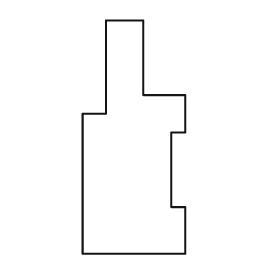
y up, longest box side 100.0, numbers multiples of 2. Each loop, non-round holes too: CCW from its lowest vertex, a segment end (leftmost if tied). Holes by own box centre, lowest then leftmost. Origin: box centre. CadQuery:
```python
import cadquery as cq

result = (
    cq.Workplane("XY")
    .moveTo(-22.0, -50.0)
    .lineTo(22.0, -50.0)
    .lineTo(22.0, -30.0)
    .lineTo(16.0, -30.0)
    .lineTo(16.0, 2.0)
    .lineTo(22.0, 2.0)
    .lineTo(22.0, 18.0)
    .lineTo(4.0, 18.0)
    .lineTo(4.0, 50.0)
    .lineTo(-12.0, 50.0)
    .lineTo(-12.0, 10.0)
    .lineTo(-22.0, 10.0)
    .close()
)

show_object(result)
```